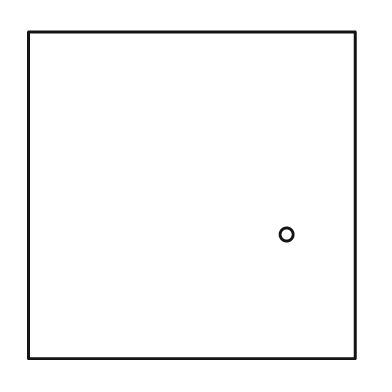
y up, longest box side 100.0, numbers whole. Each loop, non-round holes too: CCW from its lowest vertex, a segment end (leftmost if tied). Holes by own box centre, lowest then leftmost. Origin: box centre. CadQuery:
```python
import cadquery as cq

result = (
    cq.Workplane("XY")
    .moveTo(-50.0, -50.0)
    .lineTo(50.0, -50.0)
    .lineTo(50.0, 50.0)
    .lineTo(-50.0, 50.0)
    .close()
    .moveTo(29.0, -12.0)
    .circle(2.0)
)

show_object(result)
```